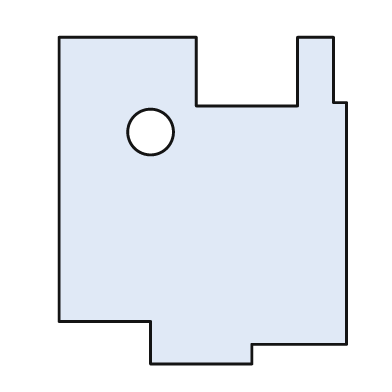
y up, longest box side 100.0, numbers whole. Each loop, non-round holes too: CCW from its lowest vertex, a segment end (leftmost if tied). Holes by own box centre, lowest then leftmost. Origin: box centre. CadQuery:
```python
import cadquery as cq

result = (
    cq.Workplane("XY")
    .moveTo(-16.0, -50.0)
    .lineTo(15.0, -50.0)
    .lineTo(15.0, -44.0)
    .lineTo(44.0, -44.0)
    .lineTo(44.0, 30.0)
    .lineTo(40.0, 30.0)
    .lineTo(40.0, 50.0)
    .lineTo(29.0, 50.0)
    .lineTo(29.0, 29.0)
    .lineTo(-2.0, 29.0)
    .lineTo(-2.0, 50.0)
    .lineTo(-44.0, 50.0)
    .lineTo(-44.0, -37.0)
    .lineTo(-16.0, -37.0)
    .close()
    .moveTo(-16.0, 21.0)
    .circle(7.0)
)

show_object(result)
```